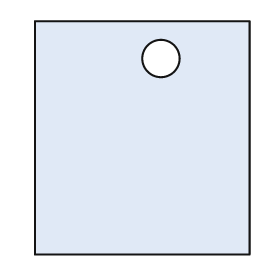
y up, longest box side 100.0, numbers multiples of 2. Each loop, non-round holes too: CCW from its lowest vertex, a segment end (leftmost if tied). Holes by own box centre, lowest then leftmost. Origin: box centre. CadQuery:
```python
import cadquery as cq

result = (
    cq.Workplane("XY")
    .moveTo(-46.0, -50.0)
    .lineTo(46.0, -50.0)
    .lineTo(46.0, 50.0)
    .lineTo(-46.0, 50.0)
    .close()
    .moveTo(8.0, 34.0)
    .circle(8.0)
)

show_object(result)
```